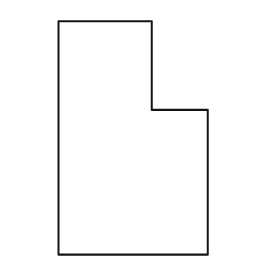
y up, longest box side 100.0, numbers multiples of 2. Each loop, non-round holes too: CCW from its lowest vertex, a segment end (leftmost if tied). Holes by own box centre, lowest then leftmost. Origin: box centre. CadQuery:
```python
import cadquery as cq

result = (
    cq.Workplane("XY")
    .moveTo(-32.0, -50.0)
    .lineTo(32.0, -50.0)
    .lineTo(32.0, 12.0)
    .lineTo(8.0, 12.0)
    .lineTo(8.0, 50.0)
    .lineTo(-32.0, 50.0)
    .close()
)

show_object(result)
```